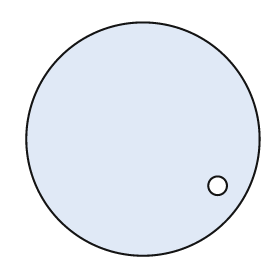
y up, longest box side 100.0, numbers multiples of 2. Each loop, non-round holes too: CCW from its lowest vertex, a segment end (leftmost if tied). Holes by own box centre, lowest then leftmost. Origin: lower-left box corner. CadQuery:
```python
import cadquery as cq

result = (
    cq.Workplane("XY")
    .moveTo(50.0, 50.0)
    .circle(50.0)
    .moveTo(82.0, 30.0)
    .circle(4.0)
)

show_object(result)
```